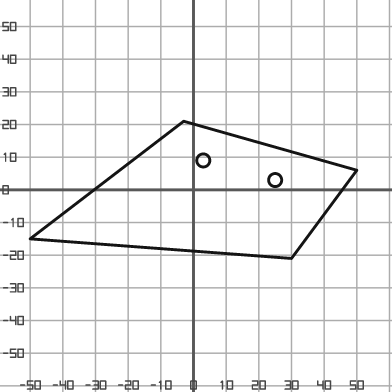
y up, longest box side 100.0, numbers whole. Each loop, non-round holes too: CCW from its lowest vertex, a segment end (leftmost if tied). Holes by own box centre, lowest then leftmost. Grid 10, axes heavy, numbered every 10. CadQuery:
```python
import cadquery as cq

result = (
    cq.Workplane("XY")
    .moveTo(30.0, -21.0)
    .lineTo(50.0, 6.0)
    .lineTo(-3.0, 21.0)
    .lineTo(-50.0, -15.0)
    .close()
    .moveTo(25.0, 3.0)
    .circle(2.0)
    .moveTo(3.0, 9.0)
    .circle(2.0)
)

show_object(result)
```